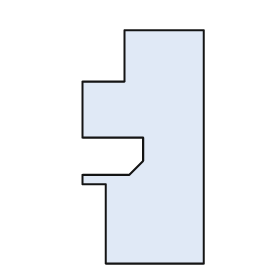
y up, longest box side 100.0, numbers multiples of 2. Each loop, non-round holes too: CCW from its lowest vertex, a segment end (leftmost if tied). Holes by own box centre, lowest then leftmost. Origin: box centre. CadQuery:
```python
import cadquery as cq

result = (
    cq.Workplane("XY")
    .moveTo(-16.0, -50.0)
    .lineTo(26.0, -50.0)
    .lineTo(26.0, 50.0)
    .lineTo(-8.0, 50.0)
    .lineTo(-8.0, 28.0)
    .lineTo(-26.0, 28.0)
    .lineTo(-26.0, 4.0)
    .lineTo(0.0, 4.0)
    .lineTo(0.0, -6.0)
    .lineTo(-6.0, -12.0)
    .lineTo(-26.0, -12.0)
    .lineTo(-26.0, -16.0)
    .lineTo(-16.0, -16.0)
    .close()
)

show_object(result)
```